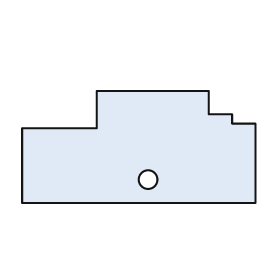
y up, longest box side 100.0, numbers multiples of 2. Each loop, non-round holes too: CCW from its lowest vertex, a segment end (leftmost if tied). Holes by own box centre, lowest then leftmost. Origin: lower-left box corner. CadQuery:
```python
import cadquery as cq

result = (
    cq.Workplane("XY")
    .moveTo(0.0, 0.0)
    .lineTo(100.0, 0.0)
    .lineTo(100.0, 34.0)
    .lineTo(90.0, 34.0)
    .lineTo(90.0, 38.0)
    .lineTo(80.0, 38.0)
    .lineTo(80.0, 48.0)
    .lineTo(32.0, 48.0)
    .lineTo(32.0, 32.0)
    .lineTo(0.0, 32.0)
    .close()
    .moveTo(54.0, 10.0)
    .circle(4.0)
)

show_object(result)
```